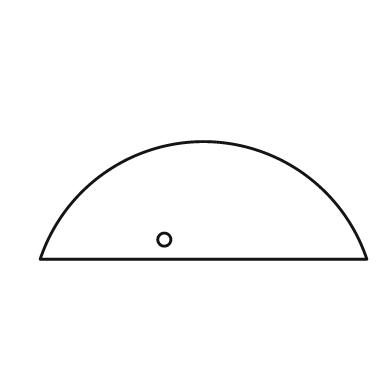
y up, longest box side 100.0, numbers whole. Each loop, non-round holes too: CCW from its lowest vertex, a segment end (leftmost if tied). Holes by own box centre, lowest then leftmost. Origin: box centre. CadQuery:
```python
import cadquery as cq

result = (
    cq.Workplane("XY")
    .moveTo(-50.0, -18.0)
    .lineTo(50.0, -18.0)
    .threePointArc((0.0, 18.0), (-50.0, -18.0))
    .close()
    .moveTo(-12.0, -12.0)
    .circle(2.0)
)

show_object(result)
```